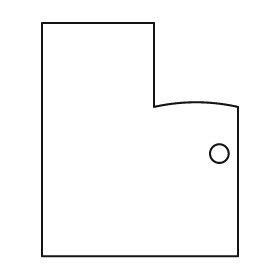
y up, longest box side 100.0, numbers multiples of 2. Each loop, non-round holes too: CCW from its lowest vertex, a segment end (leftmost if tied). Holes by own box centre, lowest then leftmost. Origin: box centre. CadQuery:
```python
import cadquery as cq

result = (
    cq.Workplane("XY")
    .moveTo(-42.0, -50.0)
    .lineTo(42.0, -50.0)
    .lineTo(42.0, 14.0)
    .threePointArc((24.0, 16.0), (6.0, 14.0))
    .lineTo(6.0, 50.0)
    .lineTo(-42.0, 50.0)
    .close()
    .moveTo(34.0, -6.0)
    .circle(4.0)
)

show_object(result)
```